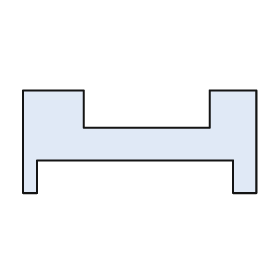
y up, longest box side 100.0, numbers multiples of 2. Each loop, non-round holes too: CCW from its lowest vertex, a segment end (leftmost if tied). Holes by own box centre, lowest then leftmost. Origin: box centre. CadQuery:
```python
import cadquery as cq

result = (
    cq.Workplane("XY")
    .moveTo(-50.0, -22.0)
    .lineTo(-44.0, -22.0)
    .lineTo(-44.0, -8.0)
    .lineTo(40.0, -8.0)
    .lineTo(40.0, -22.0)
    .lineTo(50.0, -22.0)
    .lineTo(50.0, 22.0)
    .lineTo(30.0, 22.0)
    .lineTo(30.0, 6.0)
    .lineTo(-24.0, 6.0)
    .lineTo(-24.0, 22.0)
    .lineTo(-50.0, 22.0)
    .close()
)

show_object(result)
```